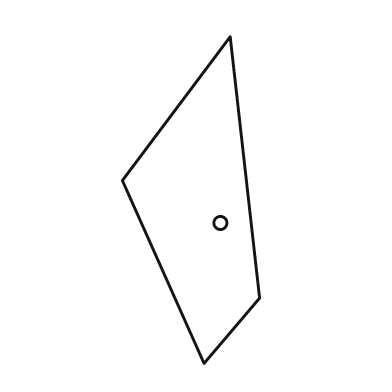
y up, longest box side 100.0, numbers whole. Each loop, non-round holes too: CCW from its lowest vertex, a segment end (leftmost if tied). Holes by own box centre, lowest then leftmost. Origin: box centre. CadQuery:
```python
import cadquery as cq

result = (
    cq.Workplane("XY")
    .moveTo(4.0, -50.0)
    .lineTo(21.0, -30.0)
    .lineTo(12.0, 50.0)
    .lineTo(-21.0, 6.0)
    .close()
    .moveTo(9.0, -7.0)
    .circle(2.0)
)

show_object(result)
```